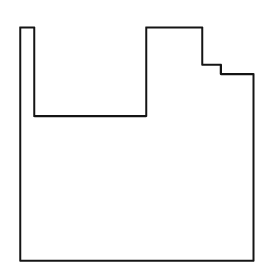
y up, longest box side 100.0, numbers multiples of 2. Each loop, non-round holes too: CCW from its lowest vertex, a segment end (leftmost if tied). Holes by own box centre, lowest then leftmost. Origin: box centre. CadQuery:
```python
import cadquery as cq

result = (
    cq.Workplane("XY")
    .moveTo(-50.0, -50.0)
    .lineTo(50.0, -50.0)
    .lineTo(50.0, 30.0)
    .lineTo(36.0, 30.0)
    .lineTo(36.0, 34.0)
    .lineTo(28.0, 34.0)
    .lineTo(28.0, 50.0)
    .lineTo(4.0, 50.0)
    .lineTo(4.0, 12.0)
    .lineTo(-44.0, 12.0)
    .lineTo(-44.0, 50.0)
    .lineTo(-50.0, 50.0)
    .close()
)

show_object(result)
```